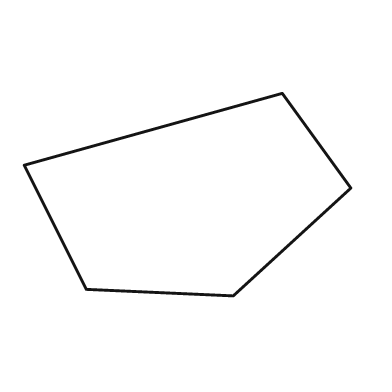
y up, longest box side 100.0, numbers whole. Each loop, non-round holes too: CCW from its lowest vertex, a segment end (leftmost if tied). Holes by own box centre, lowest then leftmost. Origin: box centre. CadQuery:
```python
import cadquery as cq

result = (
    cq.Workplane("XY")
    .moveTo(14.0, -31.0)
    .lineTo(50.0, 2.0)
    .lineTo(29.0, 31.0)
    .lineTo(-50.0, 9.0)
    .lineTo(-31.0, -29.0)
    .close()
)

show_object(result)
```